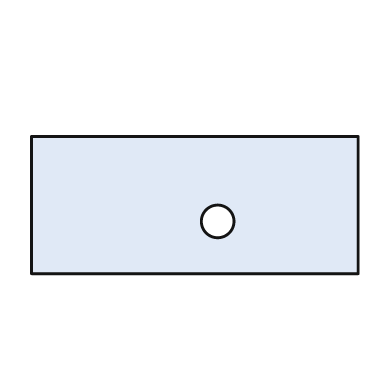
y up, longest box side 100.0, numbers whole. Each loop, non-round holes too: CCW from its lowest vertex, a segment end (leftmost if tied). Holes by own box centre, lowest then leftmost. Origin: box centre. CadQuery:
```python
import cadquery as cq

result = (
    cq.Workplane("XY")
    .moveTo(-50.0, -21.0)
    .lineTo(50.0, -21.0)
    .lineTo(50.0, 21.0)
    .lineTo(-50.0, 21.0)
    .close()
    .moveTo(7.0, -5.0)
    .circle(5.0)
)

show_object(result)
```